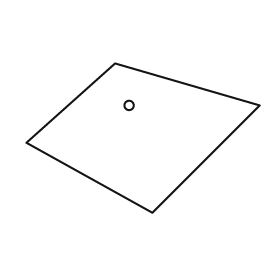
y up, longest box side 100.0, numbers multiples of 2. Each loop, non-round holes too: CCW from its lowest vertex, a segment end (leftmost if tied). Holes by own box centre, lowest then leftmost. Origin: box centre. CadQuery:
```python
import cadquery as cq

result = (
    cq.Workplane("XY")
    .moveTo(4.0, -32.0)
    .lineTo(50.0, 14.0)
    .lineTo(-12.0, 32.0)
    .lineTo(-50.0, -2.0)
    .close()
    .moveTo(-6.0, 14.0)
    .circle(2.0)
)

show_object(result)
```